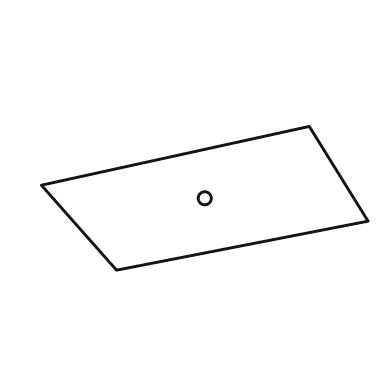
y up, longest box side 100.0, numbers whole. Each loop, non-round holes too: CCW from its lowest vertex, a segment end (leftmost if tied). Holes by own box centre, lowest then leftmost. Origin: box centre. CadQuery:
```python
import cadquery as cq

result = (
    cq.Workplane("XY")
    .moveTo(-27.0, -22.0)
    .lineTo(50.0, -7.0)
    .lineTo(32.0, 22.0)
    .lineTo(-50.0, 4.0)
    .close()
    .moveTo(0.0, 0.0)
    .circle(2.0)
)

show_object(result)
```